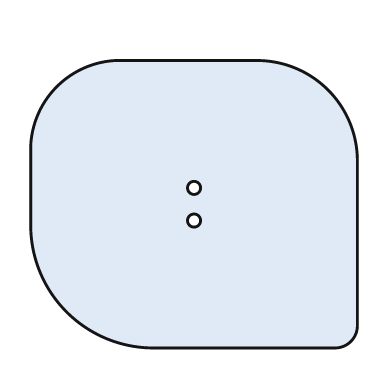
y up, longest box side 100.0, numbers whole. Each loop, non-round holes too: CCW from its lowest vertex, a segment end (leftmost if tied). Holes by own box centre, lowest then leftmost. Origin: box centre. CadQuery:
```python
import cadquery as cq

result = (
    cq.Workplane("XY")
    .moveTo(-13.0, -44.0)
    .lineTo(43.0, -44.0)
    .threePointArc((48.0, -42.0), (50.0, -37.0))
    .lineTo(50.0, 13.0)
    .threePointArc((41.0, 35.0), (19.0, 44.0))
    .lineTo(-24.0, 44.0)
    .threePointArc((-42.0, 36.0), (-50.0, 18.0))
    .lineTo(-50.0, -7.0)
    .threePointArc((-39.0, -33.0), (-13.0, -44.0))
    .close()
    .moveTo(0.0, -5.0)
    .circle(2.0)
    .moveTo(0.0, 5.0)
    .circle(2.0)
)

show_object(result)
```